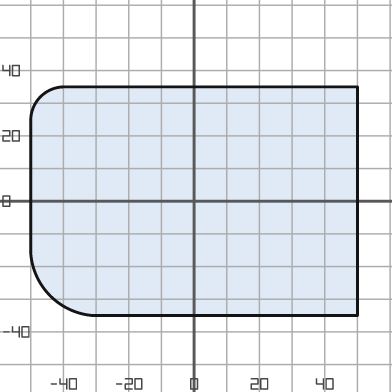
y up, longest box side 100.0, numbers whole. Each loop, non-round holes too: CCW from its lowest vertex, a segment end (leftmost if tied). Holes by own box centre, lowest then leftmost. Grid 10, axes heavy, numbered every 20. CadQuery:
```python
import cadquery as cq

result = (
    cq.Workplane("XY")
    .moveTo(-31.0, -35.0)
    .lineTo(50.0, -35.0)
    .lineTo(50.0, 35.0)
    .lineTo(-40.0, 35.0)
    .threePointArc((-47.0, 32.0), (-50.0, 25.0))
    .lineTo(-50.0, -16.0)
    .threePointArc((-44.0, -29.0), (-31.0, -35.0))
    .close()
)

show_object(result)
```